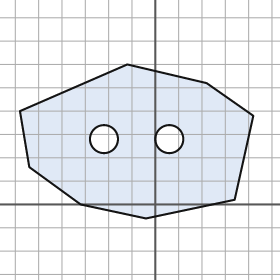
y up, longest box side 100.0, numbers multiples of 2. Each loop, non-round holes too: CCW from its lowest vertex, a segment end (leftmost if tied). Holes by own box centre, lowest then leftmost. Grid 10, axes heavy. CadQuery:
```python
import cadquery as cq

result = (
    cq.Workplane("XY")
    .moveTo(-4.0, -6.0)
    .lineTo(34.0, 2.0)
    .lineTo(42.0, 38.0)
    .lineTo(22.0, 52.0)
    .lineTo(-12.0, 60.0)
    .lineTo(-58.0, 40.0)
    .lineTo(-54.0, 16.0)
    .lineTo(-32.0, 0.0)
    .close()
    .moveTo(-22.0, 28.0)
    .circle(6.0)
    .moveTo(6.0, 28.0)
    .circle(6.0)
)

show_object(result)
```